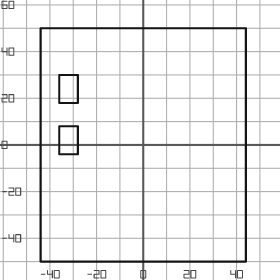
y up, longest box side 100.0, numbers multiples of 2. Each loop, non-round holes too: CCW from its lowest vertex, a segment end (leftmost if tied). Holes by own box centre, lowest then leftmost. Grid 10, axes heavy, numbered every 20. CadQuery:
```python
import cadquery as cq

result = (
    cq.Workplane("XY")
    .moveTo(-44.0, -50.0)
    .lineTo(44.0, -50.0)
    .lineTo(44.0, 50.0)
    .lineTo(-44.0, 50.0)
    .close()
    .moveTo(-36.0, -4.0)
    .lineTo(-28.0, -4.0)
    .lineTo(-28.0, 8.0)
    .lineTo(-36.0, 8.0)
    .close()
    .moveTo(-36.0, 18.0)
    .lineTo(-28.0, 18.0)
    .lineTo(-28.0, 30.0)
    .lineTo(-36.0, 30.0)
    .close()
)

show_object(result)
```